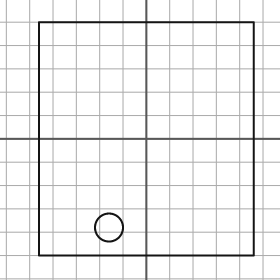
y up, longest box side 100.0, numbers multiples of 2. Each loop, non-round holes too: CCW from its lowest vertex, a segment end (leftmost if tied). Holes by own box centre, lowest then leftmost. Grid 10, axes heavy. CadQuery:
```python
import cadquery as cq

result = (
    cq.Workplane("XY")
    .moveTo(-46.0, -50.0)
    .lineTo(46.0, -50.0)
    .lineTo(46.0, 50.0)
    .lineTo(-46.0, 50.0)
    .close()
    .moveTo(-16.0, -38.0)
    .circle(6.0)
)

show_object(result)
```